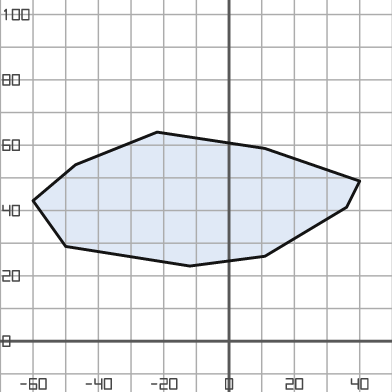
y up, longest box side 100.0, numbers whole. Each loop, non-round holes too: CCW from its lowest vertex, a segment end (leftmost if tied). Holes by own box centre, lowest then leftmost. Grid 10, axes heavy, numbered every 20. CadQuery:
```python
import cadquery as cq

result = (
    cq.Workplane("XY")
    .moveTo(-12.0, 23.0)
    .lineTo(11.0, 26.0)
    .lineTo(36.0, 41.0)
    .lineTo(40.0, 49.0)
    .lineTo(11.0, 59.0)
    .lineTo(-22.0, 64.0)
    .lineTo(-47.0, 54.0)
    .lineTo(-60.0, 43.0)
    .lineTo(-50.0, 29.0)
    .close()
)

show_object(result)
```